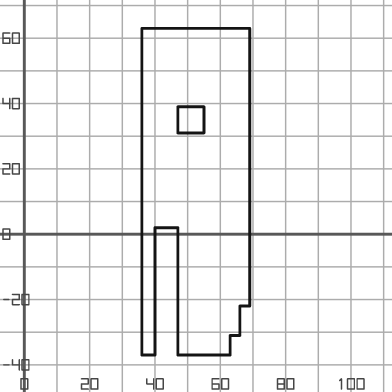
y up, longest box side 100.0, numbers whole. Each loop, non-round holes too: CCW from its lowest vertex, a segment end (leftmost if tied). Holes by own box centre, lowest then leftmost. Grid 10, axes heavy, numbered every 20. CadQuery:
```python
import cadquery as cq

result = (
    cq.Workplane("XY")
    .moveTo(36.0, -37.0)
    .lineTo(40.0, -37.0)
    .lineTo(40.0, 2.0)
    .lineTo(47.0, 2.0)
    .lineTo(47.0, -37.0)
    .lineTo(63.0, -37.0)
    .lineTo(63.0, -31.0)
    .lineTo(66.0, -31.0)
    .lineTo(66.0, -22.0)
    .lineTo(69.0, -22.0)
    .lineTo(69.0, 63.0)
    .lineTo(36.0, 63.0)
    .close()
    .moveTo(47.0, 31.0)
    .lineTo(55.0, 31.0)
    .lineTo(55.0, 39.0)
    .lineTo(47.0, 39.0)
    .close()
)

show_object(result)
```